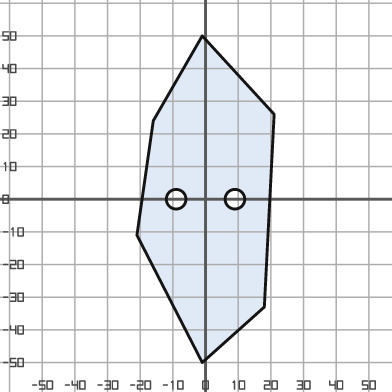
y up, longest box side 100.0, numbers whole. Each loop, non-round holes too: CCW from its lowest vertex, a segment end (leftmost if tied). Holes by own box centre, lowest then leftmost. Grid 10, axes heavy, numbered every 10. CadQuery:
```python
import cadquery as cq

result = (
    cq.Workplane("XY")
    .moveTo(-1.0, -50.0)
    .lineTo(18.0, -33.0)
    .lineTo(21.0, 26.0)
    .lineTo(-1.0, 50.0)
    .lineTo(-16.0, 24.0)
    .lineTo(-21.0, -11.0)
    .close()
    .moveTo(-9.0, 0.0)
    .circle(3.0)
    .moveTo(9.0, 0.0)
    .circle(3.0)
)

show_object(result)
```